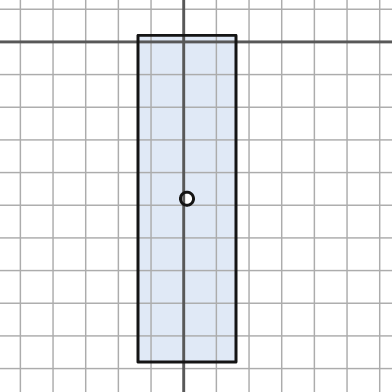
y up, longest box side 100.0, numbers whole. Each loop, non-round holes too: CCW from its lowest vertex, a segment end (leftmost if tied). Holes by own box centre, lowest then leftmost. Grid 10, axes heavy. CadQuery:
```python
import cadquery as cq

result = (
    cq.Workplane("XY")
    .moveTo(-14.0, -98.0)
    .lineTo(16.0, -98.0)
    .lineTo(16.0, 2.0)
    .lineTo(-14.0, 2.0)
    .close()
    .moveTo(1.0, -48.0)
    .circle(2.0)
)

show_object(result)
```